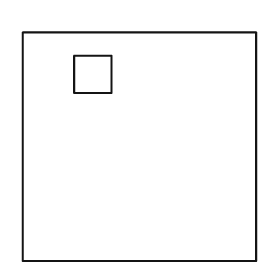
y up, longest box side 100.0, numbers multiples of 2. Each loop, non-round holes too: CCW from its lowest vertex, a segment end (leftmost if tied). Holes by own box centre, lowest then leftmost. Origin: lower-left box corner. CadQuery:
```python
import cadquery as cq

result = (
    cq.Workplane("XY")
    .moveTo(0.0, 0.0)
    .lineTo(100.0, 0.0)
    .lineTo(100.0, 98.0)
    .lineTo(0.0, 98.0)
    .close()
    .moveTo(22.0, 72.0)
    .lineTo(38.0, 72.0)
    .lineTo(38.0, 88.0)
    .lineTo(22.0, 88.0)
    .close()
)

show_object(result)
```